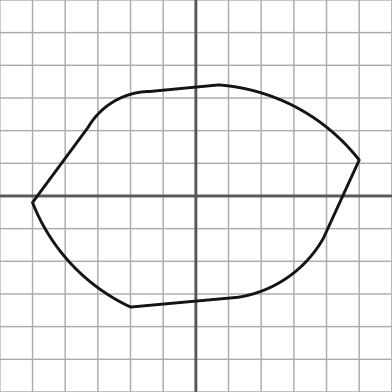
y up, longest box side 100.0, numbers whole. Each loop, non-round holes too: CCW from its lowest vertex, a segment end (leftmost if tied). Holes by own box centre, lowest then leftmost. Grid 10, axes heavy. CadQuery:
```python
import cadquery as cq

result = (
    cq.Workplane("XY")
    .moveTo(-20.0, -34.0)
    .lineTo(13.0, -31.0)
    .threePointArc((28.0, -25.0), (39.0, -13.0))
    .lineTo(50.0, 11.0)
    .threePointArc((31.0, 27.0), (7.0, 34.0))
    .lineTo(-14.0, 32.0)
    .threePointArc((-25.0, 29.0), (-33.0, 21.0))
    .lineTo(-50.0, -2.0)
    .threePointArc((-38.0, -21.0), (-20.0, -34.0))
    .close()
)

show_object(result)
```